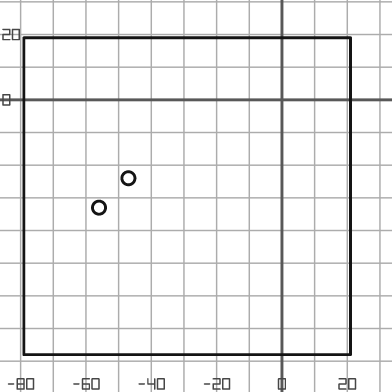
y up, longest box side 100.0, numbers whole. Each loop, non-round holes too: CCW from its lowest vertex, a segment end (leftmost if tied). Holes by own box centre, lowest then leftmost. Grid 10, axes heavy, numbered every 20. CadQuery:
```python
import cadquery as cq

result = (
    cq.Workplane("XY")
    .moveTo(-79.0, -78.0)
    .lineTo(21.0, -78.0)
    .lineTo(21.0, 19.0)
    .lineTo(-79.0, 19.0)
    .close()
    .moveTo(-56.0, -33.0)
    .circle(2.0)
    .moveTo(-47.0, -24.0)
    .circle(2.0)
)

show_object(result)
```